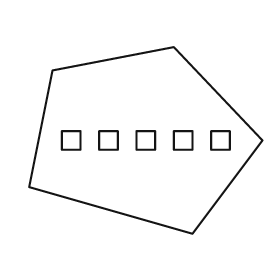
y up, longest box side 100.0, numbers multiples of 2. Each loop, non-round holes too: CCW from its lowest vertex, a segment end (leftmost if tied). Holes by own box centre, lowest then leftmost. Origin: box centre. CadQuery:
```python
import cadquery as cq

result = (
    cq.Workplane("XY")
    .moveTo(20.0, -40.0)
    .lineTo(50.0, 0.0)
    .lineTo(12.0, 40.0)
    .lineTo(-40.0, 30.0)
    .lineTo(-50.0, -20.0)
    .close()
    .moveTo(-36.0, -4.0)
    .lineTo(-28.0, -4.0)
    .lineTo(-28.0, 4.0)
    .lineTo(-36.0, 4.0)
    .close()
    .moveTo(-20.0, -4.0)
    .lineTo(-12.0, -4.0)
    .lineTo(-12.0, 4.0)
    .lineTo(-20.0, 4.0)
    .close()
    .moveTo(-4.0, -4.0)
    .lineTo(4.0, -4.0)
    .lineTo(4.0, 4.0)
    .lineTo(-4.0, 4.0)
    .close()
    .moveTo(12.0, -4.0)
    .lineTo(20.0, -4.0)
    .lineTo(20.0, 4.0)
    .lineTo(12.0, 4.0)
    .close()
    .moveTo(28.0, -4.0)
    .lineTo(36.0, -4.0)
    .lineTo(36.0, 4.0)
    .lineTo(28.0, 4.0)
    .close()
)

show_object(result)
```